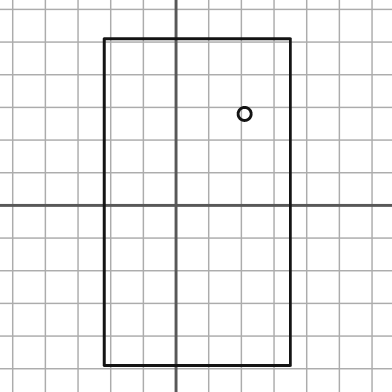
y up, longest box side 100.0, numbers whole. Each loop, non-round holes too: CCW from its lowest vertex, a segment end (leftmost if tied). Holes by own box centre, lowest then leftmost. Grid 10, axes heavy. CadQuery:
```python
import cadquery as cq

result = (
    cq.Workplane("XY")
    .moveTo(-22.0, -49.0)
    .lineTo(35.0, -49.0)
    .lineTo(35.0, 51.0)
    .lineTo(-22.0, 51.0)
    .close()
    .moveTo(21.0, 28.0)
    .circle(2.0)
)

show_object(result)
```